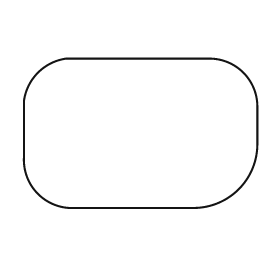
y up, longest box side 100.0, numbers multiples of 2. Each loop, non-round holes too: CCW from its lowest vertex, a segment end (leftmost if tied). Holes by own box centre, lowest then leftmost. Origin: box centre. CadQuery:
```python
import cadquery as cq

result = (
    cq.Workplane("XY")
    .moveTo(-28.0, -32.0)
    .lineTo(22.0, -32.0)
    .threePointArc((42.0, -24.0), (50.0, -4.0))
    .lineTo(50.0, 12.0)
    .threePointArc((44.0, 26.0), (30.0, 32.0))
    .lineTo(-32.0, 32.0)
    .threePointArc((-44.0, 26.0), (-50.0, 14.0))
    .lineTo(-50.0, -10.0)
    .threePointArc((-44.0, -26.0), (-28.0, -32.0))
    .close()
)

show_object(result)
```